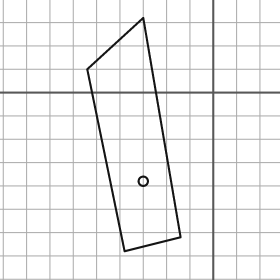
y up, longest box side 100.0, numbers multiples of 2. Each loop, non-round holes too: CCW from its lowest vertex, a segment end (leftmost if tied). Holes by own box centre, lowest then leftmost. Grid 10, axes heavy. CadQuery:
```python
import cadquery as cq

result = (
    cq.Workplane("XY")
    .moveTo(-38.0, -68.0)
    .lineTo(-14.0, -62.0)
    .lineTo(-30.0, 32.0)
    .lineTo(-54.0, 10.0)
    .close()
    .moveTo(-30.0, -38.0)
    .circle(2.0)
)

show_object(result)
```